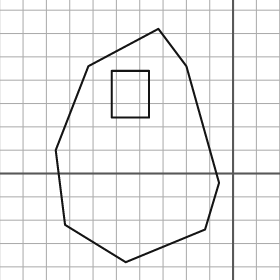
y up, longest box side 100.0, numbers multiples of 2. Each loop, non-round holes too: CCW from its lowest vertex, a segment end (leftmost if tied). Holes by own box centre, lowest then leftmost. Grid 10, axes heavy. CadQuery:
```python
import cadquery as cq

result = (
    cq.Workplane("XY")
    .moveTo(-46.0, -38.0)
    .lineTo(-12.0, -24.0)
    .lineTo(-6.0, -4.0)
    .lineTo(-20.0, 46.0)
    .lineTo(-32.0, 62.0)
    .lineTo(-62.0, 46.0)
    .lineTo(-76.0, 10.0)
    .lineTo(-72.0, -22.0)
    .close()
    .moveTo(-52.0, 24.0)
    .lineTo(-36.0, 24.0)
    .lineTo(-36.0, 44.0)
    .lineTo(-52.0, 44.0)
    .close()
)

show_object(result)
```